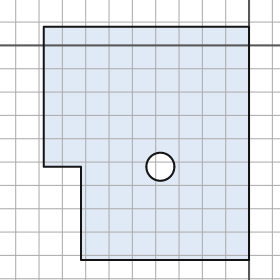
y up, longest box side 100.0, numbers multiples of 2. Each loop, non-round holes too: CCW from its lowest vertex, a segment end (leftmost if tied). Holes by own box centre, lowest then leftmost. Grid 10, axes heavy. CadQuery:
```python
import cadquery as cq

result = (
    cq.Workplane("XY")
    .moveTo(-72.0, -92.0)
    .lineTo(0.0, -92.0)
    .lineTo(0.0, 8.0)
    .lineTo(-88.0, 8.0)
    .lineTo(-88.0, -52.0)
    .lineTo(-72.0, -52.0)
    .close()
    .moveTo(-38.0, -52.0)
    .circle(6.0)
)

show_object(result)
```